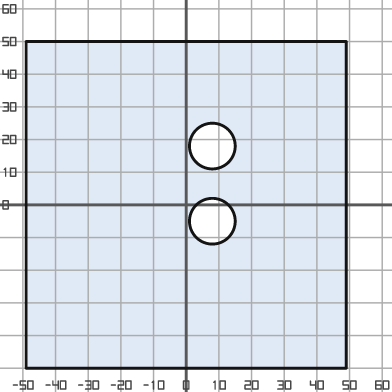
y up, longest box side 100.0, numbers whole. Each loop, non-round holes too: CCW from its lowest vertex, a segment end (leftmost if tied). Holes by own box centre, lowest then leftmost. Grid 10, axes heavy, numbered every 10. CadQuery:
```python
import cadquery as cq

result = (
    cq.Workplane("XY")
    .moveTo(-49.0, -50.0)
    .lineTo(49.0, -50.0)
    .lineTo(49.0, 50.0)
    .lineTo(-49.0, 50.0)
    .close()
    .moveTo(8.0, -5.0)
    .circle(7.0)
    .moveTo(8.0, 18.0)
    .circle(7.0)
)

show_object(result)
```